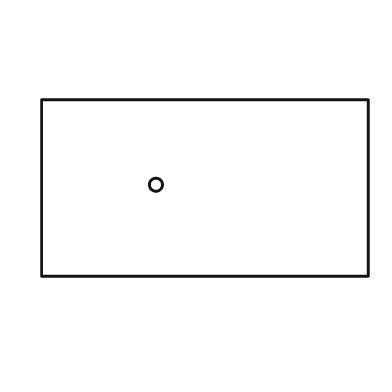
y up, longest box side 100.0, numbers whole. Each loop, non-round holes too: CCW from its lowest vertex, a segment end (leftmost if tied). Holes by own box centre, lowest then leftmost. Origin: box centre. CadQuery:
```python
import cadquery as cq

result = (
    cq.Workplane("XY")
    .moveTo(-50.0, -27.0)
    .lineTo(50.0, -27.0)
    .lineTo(50.0, 27.0)
    .lineTo(-50.0, 27.0)
    .close()
    .moveTo(-15.0, 1.0)
    .circle(2.0)
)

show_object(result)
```